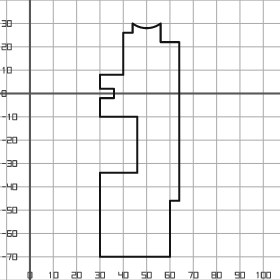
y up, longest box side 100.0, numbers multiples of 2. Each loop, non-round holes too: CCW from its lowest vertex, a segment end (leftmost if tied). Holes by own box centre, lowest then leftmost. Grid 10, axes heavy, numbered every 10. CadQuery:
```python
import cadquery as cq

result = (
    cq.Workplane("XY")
    .moveTo(30.0, -70.0)
    .lineTo(60.0, -70.0)
    .lineTo(60.0, -46.0)
    .lineTo(64.0, -46.0)
    .lineTo(64.0, 22.0)
    .lineTo(56.0, 22.0)
    .lineTo(56.0, 30.0)
    .threePointArc((50.0, 28.0), (44.0, 30.0))
    .lineTo(44.0, 26.0)
    .lineTo(40.0, 26.0)
    .lineTo(40.0, 8.0)
    .lineTo(30.0, 8.0)
    .lineTo(30.0, 2.0)
    .lineTo(36.0, 2.0)
    .lineTo(36.0, -2.0)
    .lineTo(30.0, -2.0)
    .lineTo(30.0, -10.0)
    .lineTo(46.0, -10.0)
    .lineTo(46.0, -34.0)
    .lineTo(30.0, -34.0)
    .close()
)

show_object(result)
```